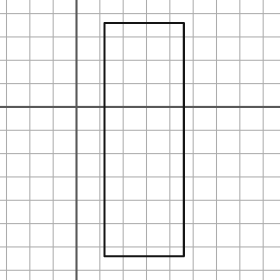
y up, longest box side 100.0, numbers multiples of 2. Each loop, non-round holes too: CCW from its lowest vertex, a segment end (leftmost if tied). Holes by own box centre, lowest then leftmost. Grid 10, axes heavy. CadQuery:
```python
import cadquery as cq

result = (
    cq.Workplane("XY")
    .moveTo(12.0, -64.0)
    .lineTo(46.0, -64.0)
    .lineTo(46.0, 36.0)
    .lineTo(12.0, 36.0)
    .close()
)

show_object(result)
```